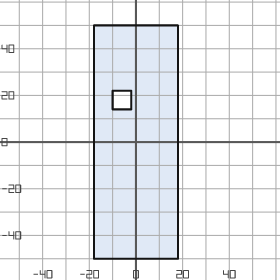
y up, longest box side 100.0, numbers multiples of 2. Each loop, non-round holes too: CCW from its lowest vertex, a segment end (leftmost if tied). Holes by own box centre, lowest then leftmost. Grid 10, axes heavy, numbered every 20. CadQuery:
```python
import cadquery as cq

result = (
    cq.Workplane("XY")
    .moveTo(-18.0, -50.0)
    .lineTo(18.0, -50.0)
    .lineTo(18.0, 50.0)
    .lineTo(-18.0, 50.0)
    .close()
    .moveTo(-10.0, 14.0)
    .lineTo(-2.0, 14.0)
    .lineTo(-2.0, 22.0)
    .lineTo(-10.0, 22.0)
    .close()
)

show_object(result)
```